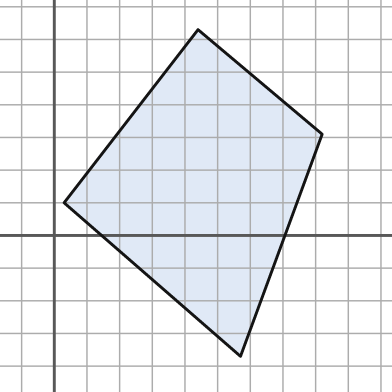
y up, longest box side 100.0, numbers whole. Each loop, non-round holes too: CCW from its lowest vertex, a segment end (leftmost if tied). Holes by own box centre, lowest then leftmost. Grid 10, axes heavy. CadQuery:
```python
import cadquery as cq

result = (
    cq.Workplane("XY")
    .moveTo(57.0, -37.0)
    .lineTo(82.0, 31.0)
    .lineTo(44.0, 63.0)
    .lineTo(3.0, 10.0)
    .close()
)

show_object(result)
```